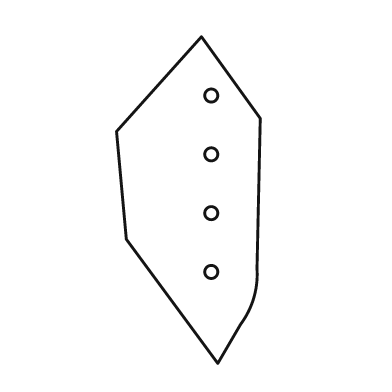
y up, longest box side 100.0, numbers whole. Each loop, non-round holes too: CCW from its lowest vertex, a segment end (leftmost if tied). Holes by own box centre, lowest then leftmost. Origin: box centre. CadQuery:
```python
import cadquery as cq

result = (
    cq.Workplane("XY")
    .moveTo(9.0, -50.0)
    .lineTo(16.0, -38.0)
    .threePointArc((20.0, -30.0), (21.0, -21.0))
    .lineTo(22.0, 25.0)
    .lineTo(4.0, 50.0)
    .lineTo(-22.0, 21.0)
    .lineTo(-19.0, -12.0)
    .close()
    .moveTo(7.0, -22.0)
    .circle(2.0)
    .moveTo(7.0, -4.0)
    .circle(2.0)
    .moveTo(7.0, 14.0)
    .circle(2.0)
    .moveTo(7.0, 32.0)
    .circle(2.0)
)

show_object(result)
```